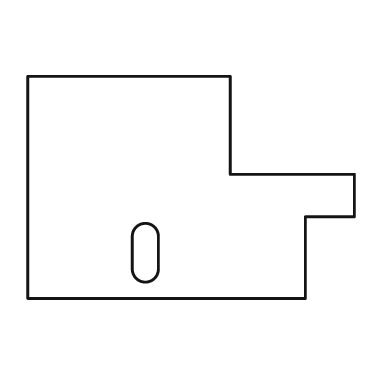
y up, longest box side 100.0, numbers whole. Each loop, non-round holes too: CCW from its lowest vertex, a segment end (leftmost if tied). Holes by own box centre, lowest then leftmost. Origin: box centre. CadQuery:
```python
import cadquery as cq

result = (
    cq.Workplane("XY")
    .moveTo(-50.0, -34.0)
    .lineTo(35.0, -34.0)
    .lineTo(35.0, -9.0)
    .lineTo(50.0, -9.0)
    .lineTo(50.0, 4.0)
    .lineTo(12.0, 4.0)
    .lineTo(12.0, 34.0)
    .lineTo(-50.0, 34.0)
    .close()
    .moveTo(-18.0, -25.0)
    .threePointArc((-14.0, -29.0), (-10.0, -25.0))
    .lineTo(-10.0, -15.0)
    .threePointArc((-14.0, -11.0), (-18.0, -15.0))
    .close()
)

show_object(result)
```